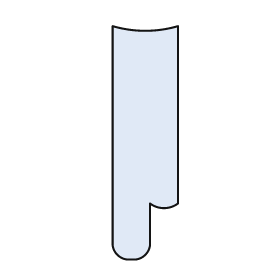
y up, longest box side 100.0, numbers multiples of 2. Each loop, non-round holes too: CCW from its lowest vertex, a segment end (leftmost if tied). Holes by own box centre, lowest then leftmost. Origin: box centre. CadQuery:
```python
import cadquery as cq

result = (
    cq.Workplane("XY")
    .moveTo(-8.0, -50.0)
    .lineTo(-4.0, -50.0)
    .threePointArc((0.0, -48.0), (2.0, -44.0))
    .lineTo(2.0, -26.0)
    .threePointArc((8.0, -28.0), (14.0, -26.0))
    .lineTo(14.0, 50.0)
    .threePointArc((0.0, 48.0), (-14.0, 50.0))
    .lineTo(-14.0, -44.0)
    .threePointArc((-12.0, -48.0), (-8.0, -50.0))
    .close()
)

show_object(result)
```